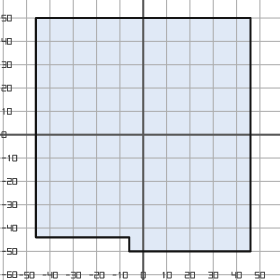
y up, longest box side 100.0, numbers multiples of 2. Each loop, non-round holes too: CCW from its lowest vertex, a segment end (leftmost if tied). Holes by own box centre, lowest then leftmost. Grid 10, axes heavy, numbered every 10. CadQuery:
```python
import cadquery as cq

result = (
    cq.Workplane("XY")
    .moveTo(-6.0, -50.0)
    .lineTo(46.0, -50.0)
    .lineTo(46.0, 50.0)
    .lineTo(-46.0, 50.0)
    .lineTo(-46.0, -44.0)
    .lineTo(-6.0, -44.0)
    .close()
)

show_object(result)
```